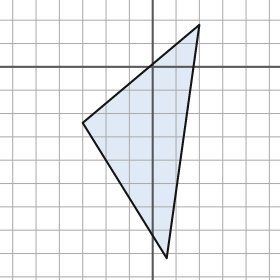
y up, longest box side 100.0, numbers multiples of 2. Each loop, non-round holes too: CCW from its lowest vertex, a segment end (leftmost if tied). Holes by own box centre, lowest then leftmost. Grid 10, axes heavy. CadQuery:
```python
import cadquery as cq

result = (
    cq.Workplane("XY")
    .moveTo(6.0, -82.0)
    .lineTo(20.0, 18.0)
    .lineTo(-30.0, -24.0)
    .close()
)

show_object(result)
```